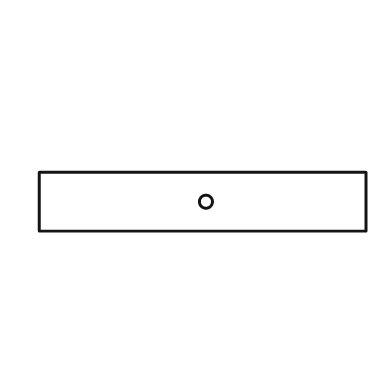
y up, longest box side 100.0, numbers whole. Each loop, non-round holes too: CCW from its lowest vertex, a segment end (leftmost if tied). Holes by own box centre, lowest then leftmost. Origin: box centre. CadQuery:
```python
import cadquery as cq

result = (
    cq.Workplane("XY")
    .moveTo(-50.0, -9.0)
    .lineTo(50.0, -9.0)
    .lineTo(50.0, 9.0)
    .lineTo(-50.0, 9.0)
    .close()
    .moveTo(1.0, 0.0)
    .circle(2.0)
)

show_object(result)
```